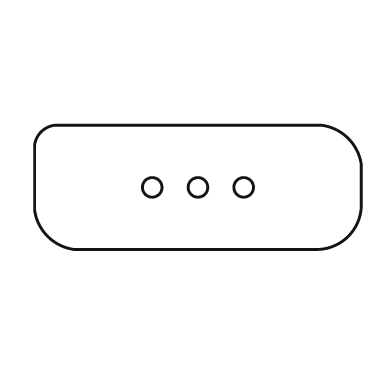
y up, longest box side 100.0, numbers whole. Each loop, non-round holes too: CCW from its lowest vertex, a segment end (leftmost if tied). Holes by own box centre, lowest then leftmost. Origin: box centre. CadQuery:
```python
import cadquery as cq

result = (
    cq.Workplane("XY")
    .moveTo(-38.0, -19.0)
    .lineTo(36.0, -19.0)
    .threePointArc((46.0, -15.0), (50.0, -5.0))
    .lineTo(50.0, 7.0)
    .threePointArc((46.0, 15.0), (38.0, 19.0))
    .lineTo(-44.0, 19.0)
    .threePointArc((-48.0, 17.0), (-50.0, 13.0))
    .lineTo(-50.0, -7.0)
    .threePointArc((-46.0, -15.0), (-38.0, -19.0))
    .close()
    .moveTo(-14.0, 0.0)
    .circle(3.0)
    .moveTo(0.0, 0.0)
    .circle(3.0)
    .moveTo(14.0, 0.0)
    .circle(3.0)
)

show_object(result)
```